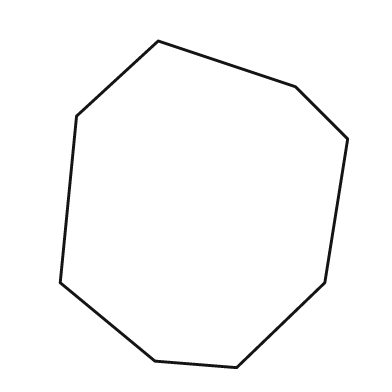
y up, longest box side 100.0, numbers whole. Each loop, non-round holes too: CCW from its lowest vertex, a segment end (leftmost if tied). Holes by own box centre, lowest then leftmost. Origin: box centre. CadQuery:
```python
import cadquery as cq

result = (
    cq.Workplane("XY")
    .moveTo(10.0, -50.0)
    .lineTo(37.0, -24.0)
    .lineTo(44.0, 20.0)
    .lineTo(28.0, 36.0)
    .lineTo(-14.0, 50.0)
    .lineTo(-39.0, 27.0)
    .lineTo(-44.0, -24.0)
    .lineTo(-15.0, -48.0)
    .close()
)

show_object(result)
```